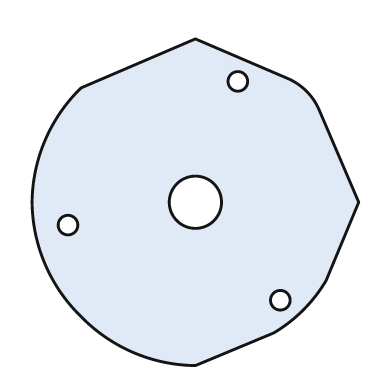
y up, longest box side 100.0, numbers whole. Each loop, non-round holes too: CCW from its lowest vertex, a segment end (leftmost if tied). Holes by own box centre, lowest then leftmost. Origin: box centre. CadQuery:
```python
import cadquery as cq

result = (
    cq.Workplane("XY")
    .moveTo(0.0, -50.0)
    .lineTo(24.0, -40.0)
    .threePointArc((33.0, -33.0), (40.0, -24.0))
    .lineTo(50.0, 0.0)
    .lineTo(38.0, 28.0)
    .threePointArc((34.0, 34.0), (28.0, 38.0))
    .lineTo(0.0, 50.0)
    .lineTo(-35.0, 35.0)
    .threePointArc((-46.0, 19.0), (-50.0, 0.0))
    .threePointArc((-46.0, -19.0), (-35.0, -35.0))
    .threePointArc((-19.0, -46.0), (0.0, -50.0))
    .close()
    .moveTo(26.0, -30.0)
    .circle(3.0)
    .moveTo(-39.0, -7.0)
    .circle(3.0)
    .moveTo(0.0, 0.0)
    .circle(8.0)
    .moveTo(13.0, 37.0)
    .circle(3.0)
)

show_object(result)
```